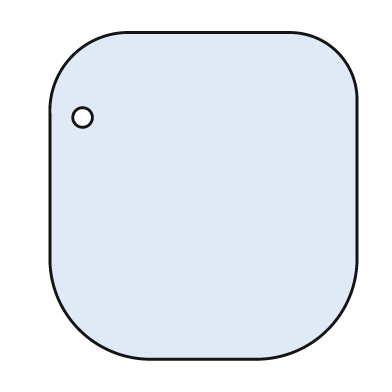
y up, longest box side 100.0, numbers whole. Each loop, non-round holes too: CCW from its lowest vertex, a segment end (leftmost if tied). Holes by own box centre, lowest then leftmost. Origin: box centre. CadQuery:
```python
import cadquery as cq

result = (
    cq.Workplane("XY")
    .moveTo(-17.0, -50.0)
    .lineTo(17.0, -50.0)
    .threePointArc((38.0, -41.0), (47.0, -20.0))
    .lineTo(47.0, 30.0)
    .threePointArc((41.0, 44.0), (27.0, 50.0))
    .lineTo(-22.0, 50.0)
    .threePointArc((-40.0, 43.0), (-47.0, 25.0))
    .lineTo(-47.0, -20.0)
    .threePointArc((-38.0, -41.0), (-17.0, -50.0))
    .close()
    .moveTo(-37.0, 24.0)
    .circle(3.0)
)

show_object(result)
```